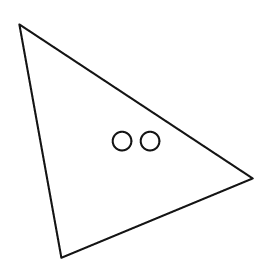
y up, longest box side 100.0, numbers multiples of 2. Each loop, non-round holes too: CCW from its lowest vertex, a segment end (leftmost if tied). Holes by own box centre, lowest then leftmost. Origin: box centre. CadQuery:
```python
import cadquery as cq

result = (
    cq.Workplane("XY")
    .moveTo(-32.0, -50.0)
    .lineTo(50.0, -16.0)
    .lineTo(-50.0, 50.0)
    .close()
    .moveTo(-6.0, 0.0)
    .circle(4.0)
    .moveTo(6.0, 0.0)
    .circle(4.0)
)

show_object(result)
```